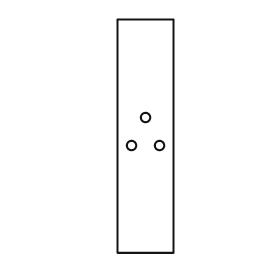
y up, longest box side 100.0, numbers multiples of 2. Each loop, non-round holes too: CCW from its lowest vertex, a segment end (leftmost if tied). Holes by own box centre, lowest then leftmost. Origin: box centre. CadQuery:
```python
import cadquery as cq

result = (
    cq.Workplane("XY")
    .moveTo(-12.0, -50.0)
    .lineTo(12.0, -50.0)
    .lineTo(12.0, 50.0)
    .lineTo(-12.0, 50.0)
    .close()
    .moveTo(-6.0, -4.0)
    .circle(2.0)
    .moveTo(6.0, -4.0)
    .circle(2.0)
    .moveTo(0.0, 8.0)
    .circle(2.0)
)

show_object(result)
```